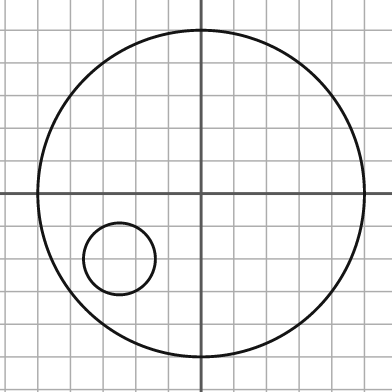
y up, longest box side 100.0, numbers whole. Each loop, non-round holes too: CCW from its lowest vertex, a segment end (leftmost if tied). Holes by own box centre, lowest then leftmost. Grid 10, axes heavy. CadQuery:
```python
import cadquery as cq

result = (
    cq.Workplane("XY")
    .moveTo(0.0, 0.0)
    .circle(50.0)
    .moveTo(-25.0, -20.0)
    .circle(11.0)
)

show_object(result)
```